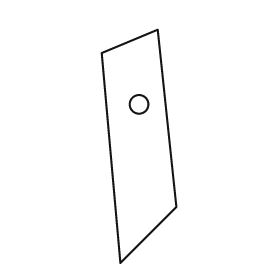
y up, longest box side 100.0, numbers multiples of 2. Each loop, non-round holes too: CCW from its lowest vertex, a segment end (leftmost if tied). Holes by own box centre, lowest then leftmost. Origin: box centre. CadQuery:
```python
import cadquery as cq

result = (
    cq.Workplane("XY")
    .moveTo(-8.0, -50.0)
    .lineTo(16.0, -26.0)
    .lineTo(8.0, 50.0)
    .lineTo(-16.0, 40.0)
    .close()
    .moveTo(0.0, 18.0)
    .circle(4.0)
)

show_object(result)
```